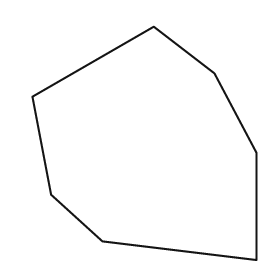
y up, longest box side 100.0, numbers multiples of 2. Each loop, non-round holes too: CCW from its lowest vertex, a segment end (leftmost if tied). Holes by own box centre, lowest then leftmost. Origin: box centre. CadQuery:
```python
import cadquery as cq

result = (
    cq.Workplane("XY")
    .moveTo(48.0, -50.0)
    .lineTo(48.0, -4.0)
    .lineTo(30.0, 30.0)
    .lineTo(4.0, 50.0)
    .lineTo(-48.0, 20.0)
    .lineTo(-40.0, -22.0)
    .lineTo(-18.0, -42.0)
    .close()
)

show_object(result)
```